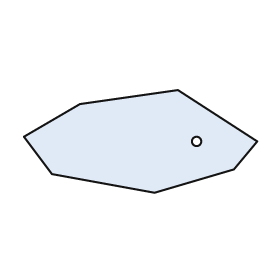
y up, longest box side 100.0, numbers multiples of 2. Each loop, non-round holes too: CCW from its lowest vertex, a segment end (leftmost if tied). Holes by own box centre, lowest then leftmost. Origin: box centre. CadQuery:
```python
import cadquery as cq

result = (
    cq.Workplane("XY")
    .moveTo(6.0, -22.0)
    .lineTo(40.0, -12.0)
    .lineTo(50.0, 0.0)
    .lineTo(16.0, 22.0)
    .lineTo(-26.0, 16.0)
    .lineTo(-50.0, 2.0)
    .lineTo(-38.0, -14.0)
    .close()
    .moveTo(24.0, 0.0)
    .circle(2.0)
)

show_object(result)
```